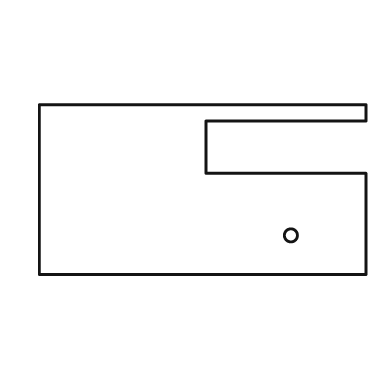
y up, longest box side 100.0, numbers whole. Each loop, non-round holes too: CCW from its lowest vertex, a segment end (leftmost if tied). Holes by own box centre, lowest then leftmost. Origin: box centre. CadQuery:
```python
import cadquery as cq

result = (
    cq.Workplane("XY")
    .moveTo(-50.0, -26.0)
    .lineTo(50.0, -26.0)
    .lineTo(50.0, 5.0)
    .lineTo(1.0, 5.0)
    .lineTo(1.0, 21.0)
    .lineTo(50.0, 21.0)
    .lineTo(50.0, 26.0)
    .lineTo(-50.0, 26.0)
    .close()
    .moveTo(27.0, -14.0)
    .circle(2.0)
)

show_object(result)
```